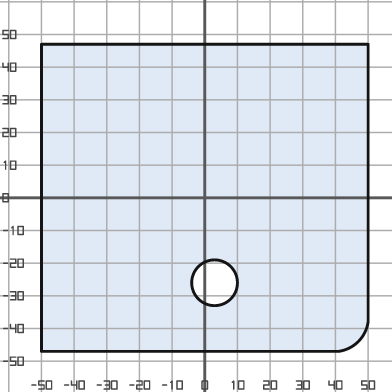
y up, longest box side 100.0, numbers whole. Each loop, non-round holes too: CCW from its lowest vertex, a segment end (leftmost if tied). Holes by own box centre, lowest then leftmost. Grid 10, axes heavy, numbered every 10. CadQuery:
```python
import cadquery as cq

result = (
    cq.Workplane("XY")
    .moveTo(-50.0, -47.0)
    .lineTo(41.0, -47.0)
    .threePointArc((47.0, -44.0), (50.0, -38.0))
    .lineTo(50.0, 47.0)
    .lineTo(-50.0, 47.0)
    .close()
    .moveTo(3.0, -26.0)
    .circle(7.0)
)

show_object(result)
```